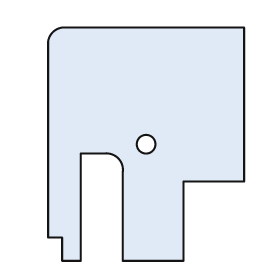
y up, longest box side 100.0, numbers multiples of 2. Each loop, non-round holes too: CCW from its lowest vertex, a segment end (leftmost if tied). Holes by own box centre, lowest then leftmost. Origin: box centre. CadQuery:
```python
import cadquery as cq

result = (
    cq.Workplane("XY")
    .moveTo(-36.0, -50.0)
    .lineTo(-28.0, -50.0)
    .lineTo(-28.0, -4.0)
    .lineTo(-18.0, -4.0)
    .threePointArc((-12.0, -6.0), (-10.0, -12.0))
    .lineTo(-10.0, -50.0)
    .lineTo(16.0, -50.0)
    .lineTo(16.0, -16.0)
    .lineTo(42.0, -16.0)
    .lineTo(42.0, 50.0)
    .lineTo(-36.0, 50.0)
    .threePointArc((-40.0, 48.0), (-42.0, 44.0))
    .lineTo(-42.0, -40.0)
    .lineTo(-36.0, -40.0)
    .close()
    .moveTo(0.0, 0.0)
    .circle(4.0)
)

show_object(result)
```